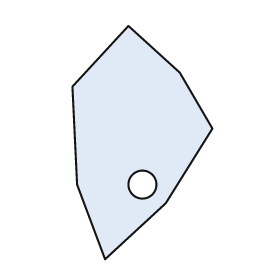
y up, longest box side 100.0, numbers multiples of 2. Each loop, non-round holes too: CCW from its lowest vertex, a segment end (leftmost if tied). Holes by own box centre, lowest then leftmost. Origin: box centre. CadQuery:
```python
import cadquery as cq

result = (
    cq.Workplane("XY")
    .moveTo(-16.0, -50.0)
    .lineTo(10.0, -26.0)
    .lineTo(30.0, 6.0)
    .lineTo(16.0, 30.0)
    .lineTo(-6.0, 50.0)
    .lineTo(-30.0, 24.0)
    .lineTo(-28.0, -18.0)
    .close()
    .moveTo(0.0, -18.0)
    .circle(6.0)
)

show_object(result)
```